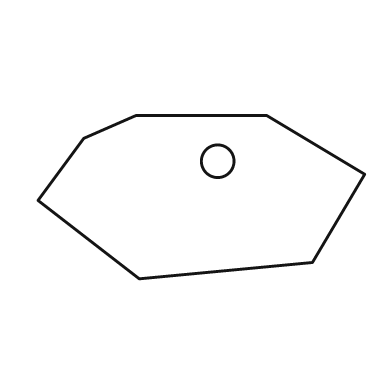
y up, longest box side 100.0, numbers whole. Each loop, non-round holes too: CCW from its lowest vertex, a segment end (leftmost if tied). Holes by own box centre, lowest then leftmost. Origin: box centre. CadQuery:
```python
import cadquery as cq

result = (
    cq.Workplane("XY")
    .moveTo(-19.0, -25.0)
    .lineTo(34.0, -20.0)
    .lineTo(50.0, 7.0)
    .lineTo(20.0, 25.0)
    .lineTo(-20.0, 25.0)
    .lineTo(-36.0, 18.0)
    .lineTo(-50.0, -1.0)
    .close()
    .moveTo(5.0, 11.0)
    .circle(5.0)
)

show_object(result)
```